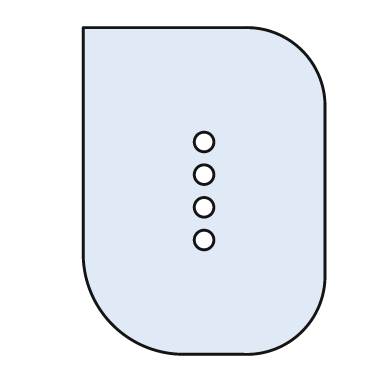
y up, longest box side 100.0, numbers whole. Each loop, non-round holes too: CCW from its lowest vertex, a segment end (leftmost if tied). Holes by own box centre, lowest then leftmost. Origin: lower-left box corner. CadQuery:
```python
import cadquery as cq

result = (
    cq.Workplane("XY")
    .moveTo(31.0, 0.0)
    .lineTo(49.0, 0.0)
    .threePointArc((67.0, 7.0), (74.0, 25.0))
    .lineTo(74.0, 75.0)
    .threePointArc((67.0, 93.0), (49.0, 100.0))
    .lineTo(0.0, 100.0)
    .lineTo(0.0, 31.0)
    .threePointArc((9.0, 9.0), (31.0, 0.0))
    .close()
    .moveTo(37.0, 35.0)
    .circle(3.0)
    .moveTo(37.0, 45.0)
    .circle(3.0)
    .moveTo(37.0, 55.0)
    .circle(3.0)
    .moveTo(37.0, 65.0)
    .circle(3.0)
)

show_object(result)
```